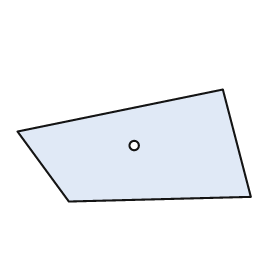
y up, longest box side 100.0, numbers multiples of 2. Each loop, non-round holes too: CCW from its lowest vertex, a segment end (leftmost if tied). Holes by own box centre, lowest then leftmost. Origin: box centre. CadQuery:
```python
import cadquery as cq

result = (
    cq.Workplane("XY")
    .moveTo(-28.0, -24.0)
    .lineTo(50.0, -22.0)
    .lineTo(38.0, 24.0)
    .lineTo(-50.0, 6.0)
    .close()
    .moveTo(0.0, 0.0)
    .circle(2.0)
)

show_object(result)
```